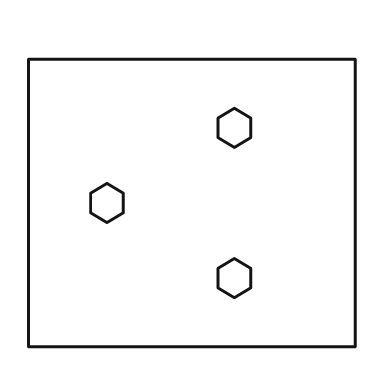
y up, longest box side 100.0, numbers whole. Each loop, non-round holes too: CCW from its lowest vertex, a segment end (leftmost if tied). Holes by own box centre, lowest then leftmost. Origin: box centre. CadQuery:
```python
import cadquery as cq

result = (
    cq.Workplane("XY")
    .moveTo(-50.0, -44.0)
    .lineTo(50.0, -44.0)
    .lineTo(50.0, 44.0)
    .lineTo(-50.0, 44.0)
    .close()
    .moveTo(13.0, -29.0)
    .lineTo(18.0, -26.0)
    .lineTo(18.0, -20.0)
    .lineTo(13.0, -17.0)
    .lineTo(8.0, -20.0)
    .lineTo(8.0, -26.0)
    .close()
    .moveTo(-26.0, -6.0)
    .lineTo(-21.0, -3.0)
    .lineTo(-21.0, 3.0)
    .lineTo(-26.0, 6.0)
    .lineTo(-31.0, 3.0)
    .lineTo(-31.0, -3.0)
    .close()
    .moveTo(13.0, 17.0)
    .lineTo(18.0, 20.0)
    .lineTo(18.0, 26.0)
    .lineTo(13.0, 29.0)
    .lineTo(8.0, 26.0)
    .lineTo(8.0, 20.0)
    .close()
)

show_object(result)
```